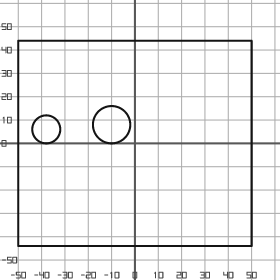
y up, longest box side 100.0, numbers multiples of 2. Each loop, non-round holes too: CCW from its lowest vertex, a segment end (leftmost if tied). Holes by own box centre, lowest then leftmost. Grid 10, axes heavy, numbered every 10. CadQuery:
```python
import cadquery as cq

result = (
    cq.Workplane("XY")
    .moveTo(-50.0, -44.0)
    .lineTo(50.0, -44.0)
    .lineTo(50.0, 44.0)
    .lineTo(-50.0, 44.0)
    .close()
    .moveTo(-38.0, 6.0)
    .circle(6.0)
    .moveTo(-10.0, 8.0)
    .circle(8.0)
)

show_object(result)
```